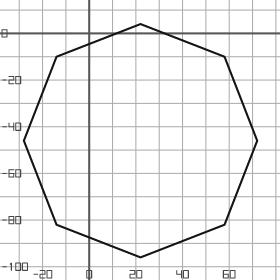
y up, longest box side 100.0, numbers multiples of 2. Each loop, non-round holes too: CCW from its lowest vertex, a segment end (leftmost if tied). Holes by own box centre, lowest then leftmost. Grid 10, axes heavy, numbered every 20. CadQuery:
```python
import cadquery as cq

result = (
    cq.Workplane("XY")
    .moveTo(22.0, -96.0)
    .lineTo(58.0, -82.0)
    .lineTo(72.0, -46.0)
    .lineTo(58.0, -10.0)
    .lineTo(22.0, 4.0)
    .lineTo(-14.0, -10.0)
    .lineTo(-28.0, -46.0)
    .lineTo(-14.0, -82.0)
    .close()
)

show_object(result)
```